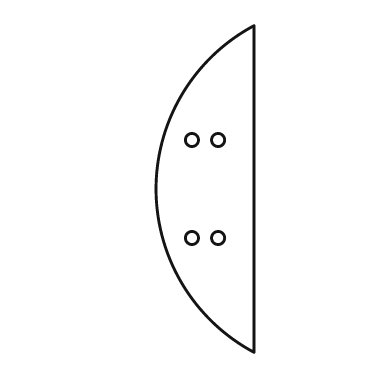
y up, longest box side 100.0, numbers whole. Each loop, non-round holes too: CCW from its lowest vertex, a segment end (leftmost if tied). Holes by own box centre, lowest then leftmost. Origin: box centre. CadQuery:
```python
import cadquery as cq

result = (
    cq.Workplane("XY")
    .moveTo(15.0, -50.0)
    .lineTo(15.0, 50.0)
    .threePointArc((-15.0, 0.0), (15.0, -50.0))
    .close()
    .moveTo(-4.0, -15.0)
    .circle(2.0)
    .moveTo(4.0, -15.0)
    .circle(2.0)
    .moveTo(-4.0, 15.0)
    .circle(2.0)
    .moveTo(4.0, 15.0)
    .circle(2.0)
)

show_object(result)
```